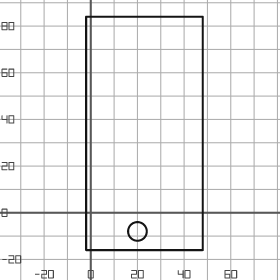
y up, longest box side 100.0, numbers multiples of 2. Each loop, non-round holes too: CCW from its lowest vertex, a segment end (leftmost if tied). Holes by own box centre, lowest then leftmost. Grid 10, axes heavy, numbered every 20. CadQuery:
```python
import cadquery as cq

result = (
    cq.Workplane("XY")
    .moveTo(-2.0, -16.0)
    .lineTo(48.0, -16.0)
    .lineTo(48.0, 84.0)
    .lineTo(-2.0, 84.0)
    .close()
    .moveTo(20.0, -8.0)
    .circle(4.0)
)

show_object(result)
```